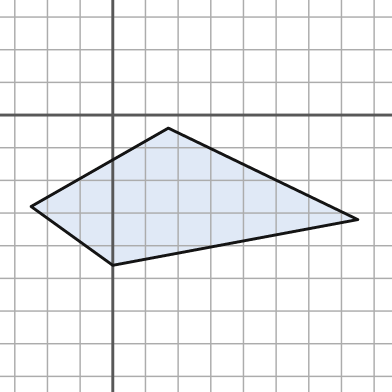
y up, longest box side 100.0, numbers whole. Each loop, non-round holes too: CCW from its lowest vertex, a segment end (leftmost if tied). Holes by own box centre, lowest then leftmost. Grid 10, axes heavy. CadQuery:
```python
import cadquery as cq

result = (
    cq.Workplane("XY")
    .moveTo(0.0, -46.0)
    .lineTo(75.0, -32.0)
    .lineTo(17.0, -4.0)
    .lineTo(-25.0, -28.0)
    .close()
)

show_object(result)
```